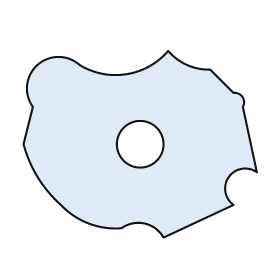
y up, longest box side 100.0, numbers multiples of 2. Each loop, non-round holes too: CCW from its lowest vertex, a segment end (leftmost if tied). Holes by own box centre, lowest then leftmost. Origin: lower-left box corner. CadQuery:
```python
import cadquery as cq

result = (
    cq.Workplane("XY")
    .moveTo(60.0, 0.0)
    .lineTo(90.0, 14.0)
    .threePointArc((88.0, 26.0), (100.0, 28.0))
    .lineTo(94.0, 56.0)
    .threePointArc((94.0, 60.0), (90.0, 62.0))
    .lineTo(80.0, 72.0)
    .threePointArc((70.0, 74.0), (62.0, 80.0))
    .threePointArc((44.0, 70.0), (24.0, 74.0))
    .threePointArc((6.0, 74.0), (4.0, 56.0))
    .lineTo(0.0, 40.0)
    .threePointArc((6.0, 26.0), (16.0, 14.0))
    .threePointArc((28.0, 6.0), (42.0, 4.0))
    .threePointArc((52.0, 6.0), (60.0, 0.0))
    .close()
    .moveTo(50.0, 40.0)
    .circle(10.0)
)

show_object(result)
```